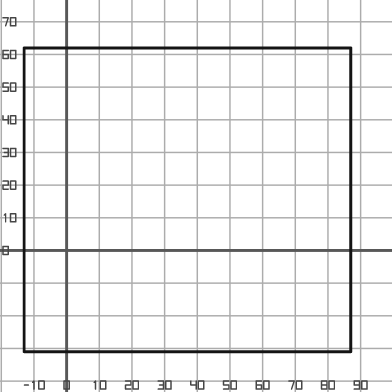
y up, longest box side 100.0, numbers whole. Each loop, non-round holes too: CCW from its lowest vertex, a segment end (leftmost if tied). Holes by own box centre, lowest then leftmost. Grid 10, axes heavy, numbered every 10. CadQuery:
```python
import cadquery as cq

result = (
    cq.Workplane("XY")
    .moveTo(-13.0, -31.0)
    .lineTo(87.0, -31.0)
    .lineTo(87.0, 62.0)
    .lineTo(-13.0, 62.0)
    .close()
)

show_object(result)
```